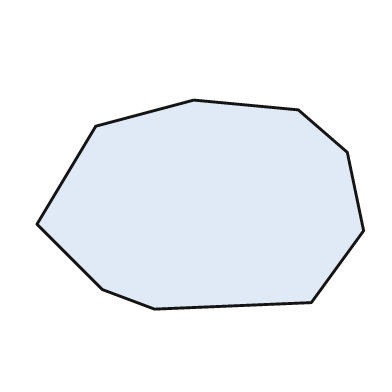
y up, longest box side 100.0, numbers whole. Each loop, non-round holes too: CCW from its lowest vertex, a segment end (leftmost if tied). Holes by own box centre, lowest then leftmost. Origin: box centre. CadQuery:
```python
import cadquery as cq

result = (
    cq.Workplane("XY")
    .moveTo(-14.0, -32.0)
    .lineTo(34.0, -30.0)
    .lineTo(50.0, -8.0)
    .lineTo(45.0, 16.0)
    .lineTo(30.0, 29.0)
    .lineTo(-2.0, 32.0)
    .lineTo(-32.0, 24.0)
    .lineTo(-50.0, -6.0)
    .lineTo(-30.0, -26.0)
    .close()
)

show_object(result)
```